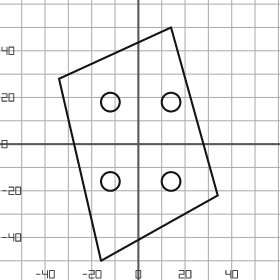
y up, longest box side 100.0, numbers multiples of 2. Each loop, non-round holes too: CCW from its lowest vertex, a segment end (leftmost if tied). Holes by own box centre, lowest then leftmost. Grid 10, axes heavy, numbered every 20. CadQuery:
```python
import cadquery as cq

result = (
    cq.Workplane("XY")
    .moveTo(-16.0, -50.0)
    .lineTo(34.0, -22.0)
    .lineTo(14.0, 50.0)
    .lineTo(-34.0, 28.0)
    .close()
    .moveTo(-12.0, -16.0)
    .circle(4.0)
    .moveTo(14.0, -16.0)
    .circle(4.0)
    .moveTo(-12.0, 18.0)
    .circle(4.0)
    .moveTo(14.0, 18.0)
    .circle(4.0)
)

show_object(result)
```